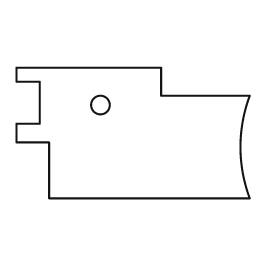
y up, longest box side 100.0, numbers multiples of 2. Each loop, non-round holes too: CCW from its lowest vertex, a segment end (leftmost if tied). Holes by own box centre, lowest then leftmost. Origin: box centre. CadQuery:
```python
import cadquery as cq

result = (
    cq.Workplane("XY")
    .moveTo(-36.0, -28.0)
    .lineTo(50.0, -28.0)
    .threePointArc((46.0, -6.0), (50.0, 16.0))
    .lineTo(12.0, 16.0)
    .lineTo(12.0, 28.0)
    .lineTo(-50.0, 28.0)
    .lineTo(-50.0, 22.0)
    .lineTo(-40.0, 22.0)
    .lineTo(-40.0, 4.0)
    .lineTo(-50.0, 4.0)
    .lineTo(-50.0, -4.0)
    .lineTo(-36.0, -4.0)
    .close()
    .moveTo(-14.0, 12.0)
    .circle(4.0)
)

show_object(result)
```